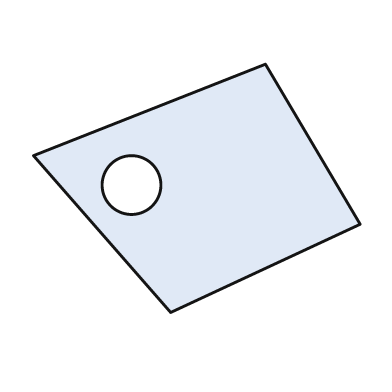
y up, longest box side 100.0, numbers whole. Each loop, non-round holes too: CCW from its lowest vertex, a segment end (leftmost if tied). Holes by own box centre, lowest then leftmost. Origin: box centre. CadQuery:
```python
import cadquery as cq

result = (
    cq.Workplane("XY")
    .moveTo(-8.0, -38.0)
    .lineTo(50.0, -11.0)
    .lineTo(21.0, 38.0)
    .lineTo(-50.0, 10.0)
    .close()
    .moveTo(-20.0, 1.0)
    .circle(9.0)
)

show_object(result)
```